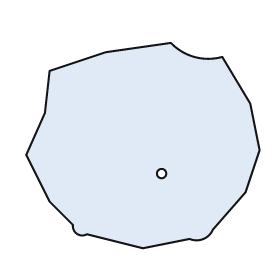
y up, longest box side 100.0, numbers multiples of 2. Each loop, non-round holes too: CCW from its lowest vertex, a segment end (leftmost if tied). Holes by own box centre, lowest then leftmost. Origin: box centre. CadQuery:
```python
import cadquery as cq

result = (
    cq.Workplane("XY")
    .moveTo(0.0, -44.0)
    .lineTo(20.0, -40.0)
    .threePointArc((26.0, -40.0), (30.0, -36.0))
    .lineTo(44.0, -20.0)
    .lineTo(50.0, -2.0)
    .lineTo(46.0, 18.0)
    .lineTo(34.0, 38.0)
    .threePointArc((22.0, 38.0), (12.0, 44.0))
    .lineTo(-16.0, 40.0)
    .lineTo(-40.0, 32.0)
    .lineTo(-42.0, 14.0)
    .lineTo(-50.0, -4.0)
    .lineTo(-40.0, -24.0)
    .lineTo(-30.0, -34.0)
    .threePointArc((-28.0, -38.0), (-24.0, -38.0))
    .close()
    .moveTo(8.0, -12.0)
    .circle(2.0)
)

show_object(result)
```